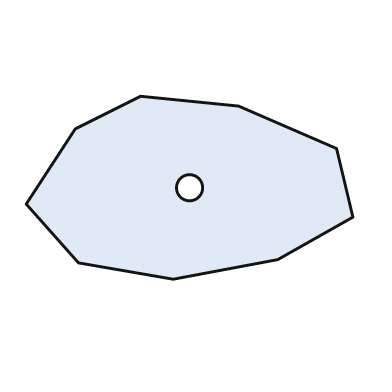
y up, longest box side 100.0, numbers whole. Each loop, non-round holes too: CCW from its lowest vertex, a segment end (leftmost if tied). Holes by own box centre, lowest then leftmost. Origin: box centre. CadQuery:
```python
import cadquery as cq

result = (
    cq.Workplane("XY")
    .moveTo(-5.0, -28.0)
    .lineTo(27.0, -22.0)
    .lineTo(50.0, -9.0)
    .lineTo(45.0, 12.0)
    .lineTo(15.0, 25.0)
    .lineTo(-15.0, 28.0)
    .lineTo(-35.0, 18.0)
    .lineTo(-50.0, -5.0)
    .lineTo(-34.0, -23.0)
    .close()
    .moveTo(0.0, 0.0)
    .circle(4.0)
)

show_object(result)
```